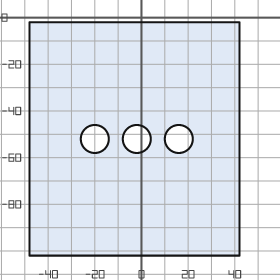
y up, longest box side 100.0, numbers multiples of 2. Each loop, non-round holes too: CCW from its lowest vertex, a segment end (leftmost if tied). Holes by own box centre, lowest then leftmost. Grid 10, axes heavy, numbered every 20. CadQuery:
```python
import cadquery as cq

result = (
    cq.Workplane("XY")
    .moveTo(-48.0, -102.0)
    .lineTo(42.0, -102.0)
    .lineTo(42.0, -2.0)
    .lineTo(-48.0, -2.0)
    .close()
    .moveTo(-20.0, -52.0)
    .circle(6.0)
    .moveTo(-2.0, -52.0)
    .circle(6.0)
    .moveTo(16.0, -52.0)
    .circle(6.0)
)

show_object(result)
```